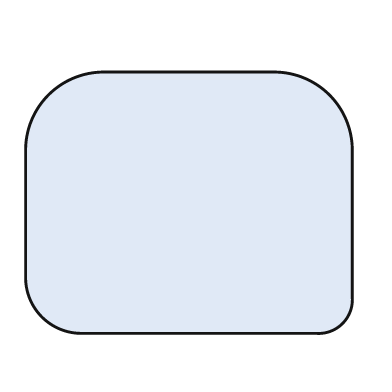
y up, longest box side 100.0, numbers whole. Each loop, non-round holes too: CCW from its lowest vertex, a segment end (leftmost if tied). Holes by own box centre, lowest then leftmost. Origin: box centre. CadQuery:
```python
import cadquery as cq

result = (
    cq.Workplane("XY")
    .moveTo(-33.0, -40.0)
    .lineTo(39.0, -40.0)
    .threePointArc((47.0, -37.0), (50.0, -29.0))
    .lineTo(50.0, 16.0)
    .threePointArc((43.0, 33.0), (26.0, 40.0))
    .lineTo(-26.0, 40.0)
    .threePointArc((-43.0, 33.0), (-50.0, 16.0))
    .lineTo(-50.0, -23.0)
    .threePointArc((-45.0, -35.0), (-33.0, -40.0))
    .close()
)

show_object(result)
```